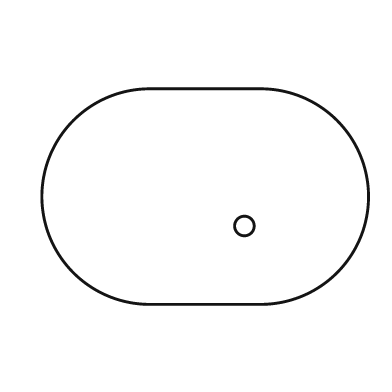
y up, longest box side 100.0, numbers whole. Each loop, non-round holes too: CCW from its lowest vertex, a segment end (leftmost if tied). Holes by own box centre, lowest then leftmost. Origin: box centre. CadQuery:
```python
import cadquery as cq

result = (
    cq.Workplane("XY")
    .moveTo(-17.0, -33.0)
    .lineTo(17.0, -33.0)
    .threePointArc((50.0, 0.0), (17.0, 33.0))
    .lineTo(-17.0, 33.0)
    .threePointArc((-50.0, 0.0), (-17.0, -33.0))
    .close()
    .moveTo(12.0, -9.0)
    .circle(3.0)
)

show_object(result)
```